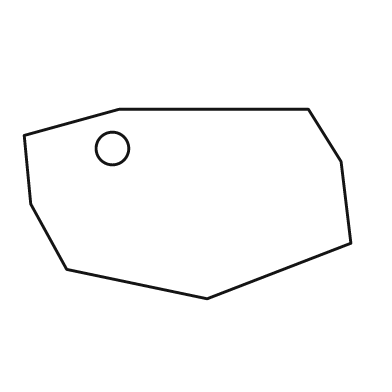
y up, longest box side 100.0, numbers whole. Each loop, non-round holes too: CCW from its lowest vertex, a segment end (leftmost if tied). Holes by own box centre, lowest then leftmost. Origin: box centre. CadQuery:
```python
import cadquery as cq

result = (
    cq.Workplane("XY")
    .moveTo(6.0, -29.0)
    .lineTo(50.0, -12.0)
    .lineTo(47.0, 13.0)
    .lineTo(37.0, 29.0)
    .lineTo(-21.0, 29.0)
    .lineTo(-50.0, 21.0)
    .lineTo(-48.0, 0.0)
    .lineTo(-37.0, -20.0)
    .close()
    .moveTo(-23.0, 17.0)
    .circle(5.0)
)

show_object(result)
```